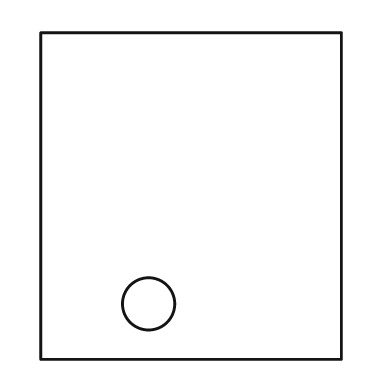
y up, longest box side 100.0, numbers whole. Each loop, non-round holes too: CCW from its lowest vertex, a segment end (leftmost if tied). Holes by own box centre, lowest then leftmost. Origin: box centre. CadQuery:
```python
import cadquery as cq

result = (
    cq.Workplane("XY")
    .moveTo(-46.0, -50.0)
    .lineTo(46.0, -50.0)
    .lineTo(46.0, 50.0)
    .lineTo(-46.0, 50.0)
    .close()
    .moveTo(-13.0, -33.0)
    .circle(8.0)
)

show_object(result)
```